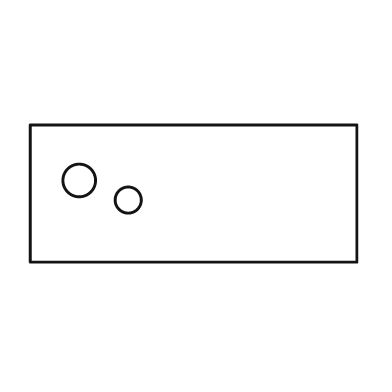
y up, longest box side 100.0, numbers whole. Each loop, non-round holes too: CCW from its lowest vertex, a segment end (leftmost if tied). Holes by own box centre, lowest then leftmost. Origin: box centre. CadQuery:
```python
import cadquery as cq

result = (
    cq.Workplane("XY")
    .moveTo(-50.0, -21.0)
    .lineTo(50.0, -21.0)
    .lineTo(50.0, 21.0)
    .lineTo(-50.0, 21.0)
    .close()
    .moveTo(-20.0, -2.0)
    .circle(4.0)
    .moveTo(-35.0, 4.0)
    .circle(5.0)
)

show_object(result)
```